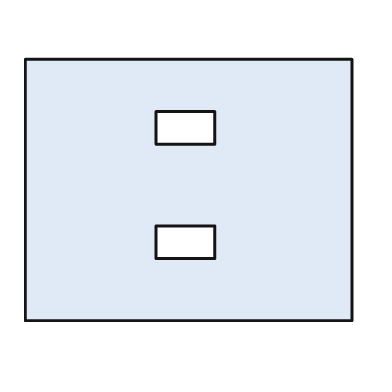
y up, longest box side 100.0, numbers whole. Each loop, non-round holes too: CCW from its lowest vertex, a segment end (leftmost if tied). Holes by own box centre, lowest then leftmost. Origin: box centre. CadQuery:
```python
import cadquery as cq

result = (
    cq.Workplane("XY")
    .moveTo(-50.0, -40.0)
    .lineTo(50.0, -40.0)
    .lineTo(50.0, 40.0)
    .lineTo(-50.0, 40.0)
    .close()
    .moveTo(-10.0, -21.0)
    .lineTo(8.0, -21.0)
    .lineTo(8.0, -11.0)
    .lineTo(-10.0, -11.0)
    .close()
    .moveTo(-10.0, 14.0)
    .lineTo(8.0, 14.0)
    .lineTo(8.0, 24.0)
    .lineTo(-10.0, 24.0)
    .close()
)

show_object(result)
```